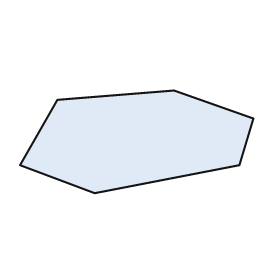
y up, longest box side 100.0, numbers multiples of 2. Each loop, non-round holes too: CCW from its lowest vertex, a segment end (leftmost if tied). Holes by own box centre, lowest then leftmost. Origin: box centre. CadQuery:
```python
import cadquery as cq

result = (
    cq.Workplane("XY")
    .moveTo(-18.0, -22.0)
    .lineTo(44.0, -10.0)
    .lineTo(50.0, 10.0)
    .lineTo(16.0, 22.0)
    .lineTo(-34.0, 18.0)
    .lineTo(-50.0, -10.0)
    .close()
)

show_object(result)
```